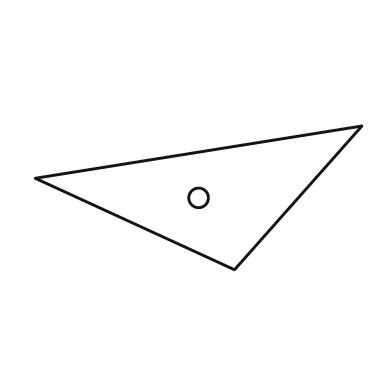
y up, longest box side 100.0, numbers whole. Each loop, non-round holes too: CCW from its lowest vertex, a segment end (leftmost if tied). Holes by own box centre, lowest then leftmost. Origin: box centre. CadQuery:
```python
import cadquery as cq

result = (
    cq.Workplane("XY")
    .moveTo(11.0, -22.0)
    .lineTo(50.0, 22.0)
    .lineTo(-50.0, 6.0)
    .close()
    .moveTo(0.0, 0.0)
    .circle(3.0)
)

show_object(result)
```